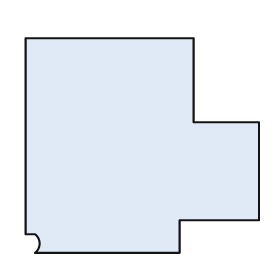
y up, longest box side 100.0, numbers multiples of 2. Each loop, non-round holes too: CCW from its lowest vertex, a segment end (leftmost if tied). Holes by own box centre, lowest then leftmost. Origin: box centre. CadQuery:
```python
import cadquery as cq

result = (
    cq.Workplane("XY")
    .moveTo(-46.0, -46.0)
    .lineTo(16.0, -46.0)
    .lineTo(16.0, -32.0)
    .lineTo(50.0, -32.0)
    .lineTo(50.0, 10.0)
    .lineTo(22.0, 10.0)
    .lineTo(22.0, 46.0)
    .lineTo(-50.0, 46.0)
    .lineTo(-50.0, -38.0)
    .lineTo(-46.0, -38.0)
    .threePointArc((-44.0, -42.0), (-46.0, -46.0))
    .close()
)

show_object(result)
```